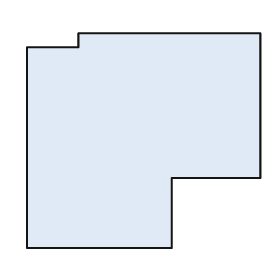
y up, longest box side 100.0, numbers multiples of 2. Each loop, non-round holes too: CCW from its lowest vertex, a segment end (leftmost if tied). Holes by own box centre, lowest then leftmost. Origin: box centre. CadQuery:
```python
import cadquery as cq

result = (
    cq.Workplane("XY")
    .moveTo(-50.0, -46.0)
    .lineTo(12.0, -46.0)
    .lineTo(12.0, -16.0)
    .lineTo(50.0, -16.0)
    .lineTo(50.0, 46.0)
    .lineTo(-28.0, 46.0)
    .lineTo(-28.0, 40.0)
    .lineTo(-50.0, 40.0)
    .close()
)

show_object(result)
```